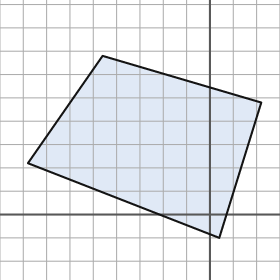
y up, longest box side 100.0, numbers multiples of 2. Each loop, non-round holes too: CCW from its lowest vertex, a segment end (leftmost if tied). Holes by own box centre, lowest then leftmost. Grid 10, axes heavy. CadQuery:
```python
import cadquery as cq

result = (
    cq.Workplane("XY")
    .moveTo(4.0, -10.0)
    .lineTo(22.0, 48.0)
    .lineTo(-46.0, 68.0)
    .lineTo(-78.0, 22.0)
    .close()
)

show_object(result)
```